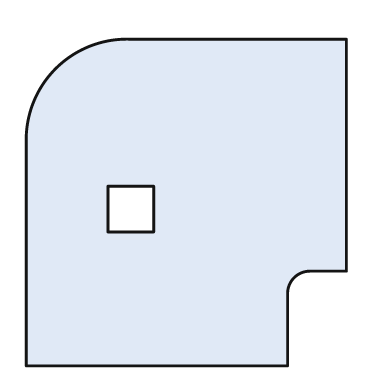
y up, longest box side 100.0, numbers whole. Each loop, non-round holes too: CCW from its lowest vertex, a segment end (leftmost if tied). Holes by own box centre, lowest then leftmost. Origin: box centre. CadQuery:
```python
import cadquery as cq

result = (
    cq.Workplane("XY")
    .moveTo(-49.0, -50.0)
    .lineTo(31.0, -50.0)
    .lineTo(31.0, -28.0)
    .threePointArc((33.0, -23.0), (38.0, -21.0))
    .lineTo(49.0, -21.0)
    .lineTo(49.0, 50.0)
    .lineTo(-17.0, 50.0)
    .threePointArc((-40.0, 41.0), (-49.0, 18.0))
    .close()
    .moveTo(-24.0, -9.0)
    .lineTo(-10.0, -9.0)
    .lineTo(-10.0, 5.0)
    .lineTo(-24.0, 5.0)
    .close()
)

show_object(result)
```